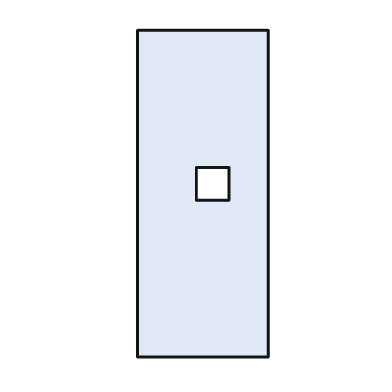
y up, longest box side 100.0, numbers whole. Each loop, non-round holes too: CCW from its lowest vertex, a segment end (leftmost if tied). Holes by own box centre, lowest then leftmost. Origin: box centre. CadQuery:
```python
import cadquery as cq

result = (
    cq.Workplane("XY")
    .moveTo(-20.0, -50.0)
    .lineTo(20.0, -50.0)
    .lineTo(20.0, 50.0)
    .lineTo(-20.0, 50.0)
    .close()
    .moveTo(-2.0, -2.0)
    .lineTo(8.0, -2.0)
    .lineTo(8.0, 8.0)
    .lineTo(-2.0, 8.0)
    .close()
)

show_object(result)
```